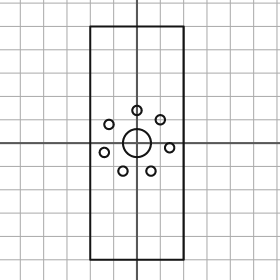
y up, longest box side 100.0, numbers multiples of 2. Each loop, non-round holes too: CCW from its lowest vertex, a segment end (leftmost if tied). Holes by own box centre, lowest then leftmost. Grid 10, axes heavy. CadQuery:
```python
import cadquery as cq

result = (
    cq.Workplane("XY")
    .moveTo(-20.0, -50.0)
    .lineTo(20.0, -50.0)
    .lineTo(20.0, 50.0)
    .lineTo(-20.0, 50.0)
    .close()
    .moveTo(-6.0, -12.0)
    .circle(2.0)
    .moveTo(6.0, -12.0)
    .circle(2.0)
    .moveTo(-14.0, -4.0)
    .circle(2.0)
    .moveTo(14.0, -2.0)
    .circle(2.0)
    .moveTo(0.0, 0.0)
    .circle(6.0)
    .moveTo(-12.0, 8.0)
    .circle(2.0)
    .moveTo(10.0, 10.0)
    .circle(2.0)
    .moveTo(0.0, 14.0)
    .circle(2.0)
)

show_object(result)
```